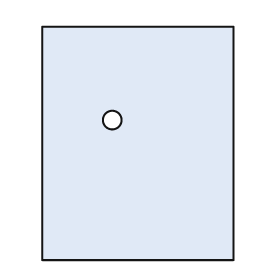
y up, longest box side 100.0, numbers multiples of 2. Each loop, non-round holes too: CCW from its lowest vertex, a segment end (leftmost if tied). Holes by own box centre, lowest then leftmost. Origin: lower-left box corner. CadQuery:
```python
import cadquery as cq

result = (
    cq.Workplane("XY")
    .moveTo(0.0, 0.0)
    .lineTo(82.0, 0.0)
    .lineTo(82.0, 100.0)
    .lineTo(0.0, 100.0)
    .close()
    .moveTo(30.0, 60.0)
    .circle(4.0)
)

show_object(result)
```